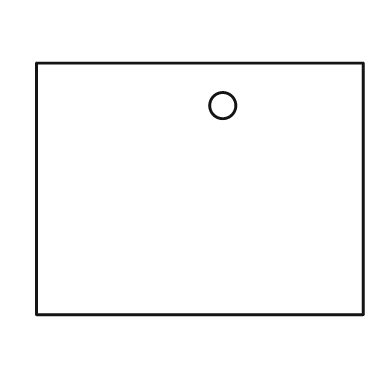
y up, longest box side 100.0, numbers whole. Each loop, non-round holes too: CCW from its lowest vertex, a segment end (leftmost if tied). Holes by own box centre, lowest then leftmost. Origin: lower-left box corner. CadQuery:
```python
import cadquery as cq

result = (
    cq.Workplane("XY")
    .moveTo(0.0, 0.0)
    .lineTo(100.0, 0.0)
    .lineTo(100.0, 77.0)
    .lineTo(0.0, 77.0)
    .close()
    .moveTo(57.0, 64.0)
    .circle(4.0)
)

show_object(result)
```